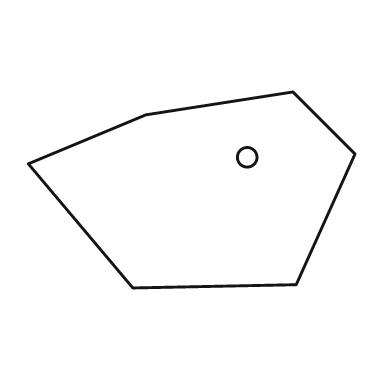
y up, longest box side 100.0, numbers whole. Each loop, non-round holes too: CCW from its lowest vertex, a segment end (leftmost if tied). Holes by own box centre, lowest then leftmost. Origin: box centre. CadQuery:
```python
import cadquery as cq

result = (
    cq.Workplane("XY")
    .moveTo(-18.0, -30.0)
    .lineTo(32.0, -29.0)
    .lineTo(50.0, 11.0)
    .lineTo(31.0, 30.0)
    .lineTo(-14.0, 23.0)
    .lineTo(-50.0, 8.0)
    .close()
    .moveTo(17.0, 10.0)
    .circle(3.0)
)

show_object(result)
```